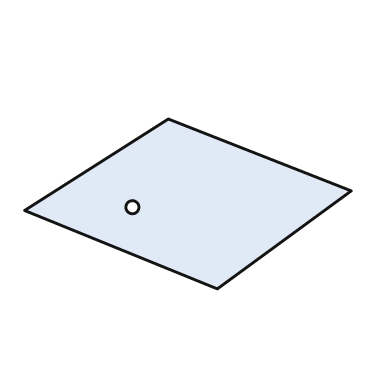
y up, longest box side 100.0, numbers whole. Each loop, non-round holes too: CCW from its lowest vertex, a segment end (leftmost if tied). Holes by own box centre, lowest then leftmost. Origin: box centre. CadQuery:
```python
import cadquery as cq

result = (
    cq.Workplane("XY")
    .moveTo(9.0, -26.0)
    .lineTo(50.0, 4.0)
    .lineTo(-6.0, 26.0)
    .lineTo(-50.0, -2.0)
    .close()
    .moveTo(-17.0, -1.0)
    .circle(2.0)
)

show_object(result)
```